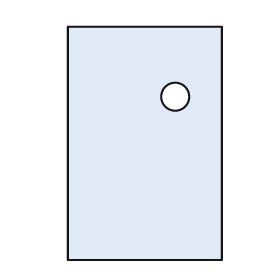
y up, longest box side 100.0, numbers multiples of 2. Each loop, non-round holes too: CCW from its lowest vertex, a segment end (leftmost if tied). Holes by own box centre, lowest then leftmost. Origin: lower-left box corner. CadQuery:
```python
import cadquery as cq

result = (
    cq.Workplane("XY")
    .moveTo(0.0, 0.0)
    .lineTo(66.0, 0.0)
    .lineTo(66.0, 100.0)
    .lineTo(0.0, 100.0)
    .close()
    .moveTo(46.0, 70.0)
    .circle(6.0)
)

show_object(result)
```